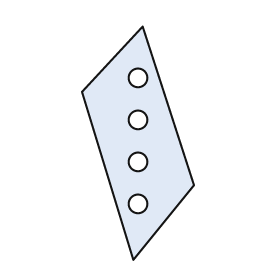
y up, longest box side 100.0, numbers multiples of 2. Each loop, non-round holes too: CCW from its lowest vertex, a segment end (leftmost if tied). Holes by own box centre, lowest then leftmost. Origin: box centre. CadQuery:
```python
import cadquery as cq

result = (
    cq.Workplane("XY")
    .moveTo(-2.0, -50.0)
    .lineTo(24.0, -18.0)
    .lineTo(2.0, 50.0)
    .lineTo(-24.0, 22.0)
    .close()
    .moveTo(0.0, -26.0)
    .circle(4.0)
    .moveTo(0.0, -8.0)
    .circle(4.0)
    .moveTo(0.0, 10.0)
    .circle(4.0)
    .moveTo(0.0, 28.0)
    .circle(4.0)
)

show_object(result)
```